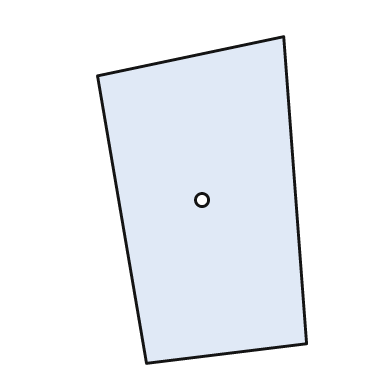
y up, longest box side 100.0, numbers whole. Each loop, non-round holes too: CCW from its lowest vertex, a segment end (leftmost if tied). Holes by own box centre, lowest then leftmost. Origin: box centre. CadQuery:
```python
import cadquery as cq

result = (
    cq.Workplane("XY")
    .moveTo(-17.0, -50.0)
    .lineTo(32.0, -44.0)
    .lineTo(25.0, 50.0)
    .lineTo(-32.0, 38.0)
    .close()
    .moveTo(0.0, 0.0)
    .circle(2.0)
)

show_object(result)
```